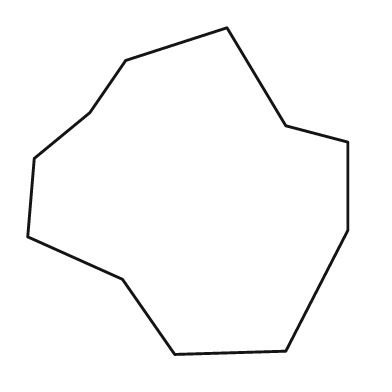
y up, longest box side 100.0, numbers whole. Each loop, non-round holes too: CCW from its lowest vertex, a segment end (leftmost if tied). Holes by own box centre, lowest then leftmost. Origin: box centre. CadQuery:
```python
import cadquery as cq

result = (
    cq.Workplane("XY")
    .moveTo(-4.0, -50.0)
    .lineTo(30.0, -49.0)
    .lineTo(49.0, -12.0)
    .lineTo(49.0, 15.0)
    .lineTo(30.0, 20.0)
    .lineTo(12.0, 50.0)
    .lineTo(-19.0, 40.0)
    .lineTo(-30.0, 24.0)
    .lineTo(-47.0, 10.0)
    .lineTo(-49.0, -14.0)
    .lineTo(-20.0, -27.0)
    .close()
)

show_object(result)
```